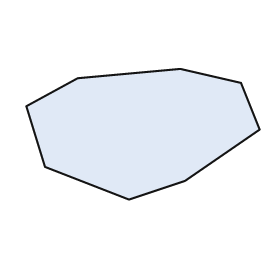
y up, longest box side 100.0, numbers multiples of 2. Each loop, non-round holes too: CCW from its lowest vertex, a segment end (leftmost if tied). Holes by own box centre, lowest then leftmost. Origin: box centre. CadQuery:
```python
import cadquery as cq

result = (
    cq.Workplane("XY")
    .moveTo(-6.0, -28.0)
    .lineTo(18.0, -20.0)
    .lineTo(50.0, 2.0)
    .lineTo(42.0, 22.0)
    .lineTo(16.0, 28.0)
    .lineTo(-28.0, 24.0)
    .lineTo(-50.0, 12.0)
    .lineTo(-42.0, -14.0)
    .close()
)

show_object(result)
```